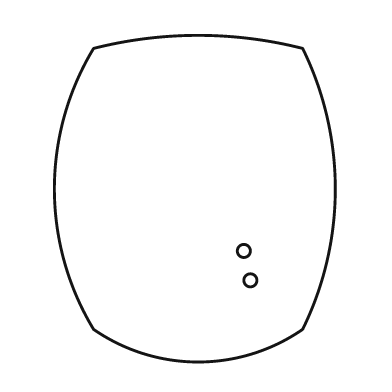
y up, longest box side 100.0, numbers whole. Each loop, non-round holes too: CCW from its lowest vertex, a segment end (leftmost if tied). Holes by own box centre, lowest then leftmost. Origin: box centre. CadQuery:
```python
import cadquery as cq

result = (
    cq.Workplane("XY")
    .moveTo(-31.0, -40.0)
    .threePointArc((1.0, -50.0), (33.0, -40.0))
    .threePointArc((43.0, 3.0), (33.0, 46.0))
    .threePointArc((1.0, 50.0), (-31.0, 46.0))
    .threePointArc((-43.0, 3.0), (-31.0, -40.0))
    .close()
    .moveTo(17.0, -25.0)
    .circle(2.0)
    .moveTo(15.0, -16.0)
    .circle(2.0)
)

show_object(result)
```